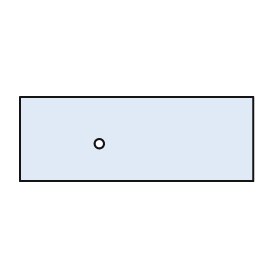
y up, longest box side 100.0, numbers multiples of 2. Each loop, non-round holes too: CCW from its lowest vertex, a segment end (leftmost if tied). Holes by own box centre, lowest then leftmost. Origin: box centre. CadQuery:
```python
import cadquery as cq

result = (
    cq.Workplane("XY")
    .moveTo(-50.0, -18.0)
    .lineTo(50.0, -18.0)
    .lineTo(50.0, 18.0)
    .lineTo(-50.0, 18.0)
    .close()
    .moveTo(-16.0, -2.0)
    .circle(2.0)
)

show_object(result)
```